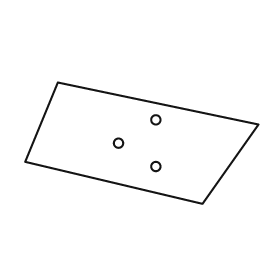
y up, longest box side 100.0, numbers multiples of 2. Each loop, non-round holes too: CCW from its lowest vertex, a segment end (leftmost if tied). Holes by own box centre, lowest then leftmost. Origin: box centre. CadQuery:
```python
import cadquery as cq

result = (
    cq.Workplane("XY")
    .moveTo(26.0, -26.0)
    .lineTo(50.0, 8.0)
    .lineTo(-36.0, 26.0)
    .lineTo(-50.0, -8.0)
    .close()
    .moveTo(6.0, -10.0)
    .circle(2.0)
    .moveTo(-10.0, 0.0)
    .circle(2.0)
    .moveTo(6.0, 10.0)
    .circle(2.0)
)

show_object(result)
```